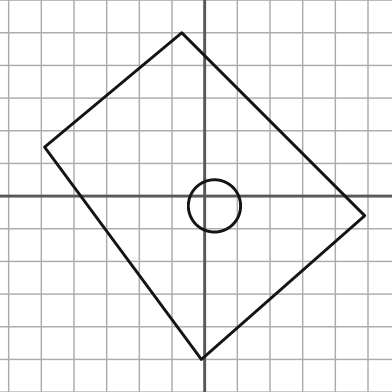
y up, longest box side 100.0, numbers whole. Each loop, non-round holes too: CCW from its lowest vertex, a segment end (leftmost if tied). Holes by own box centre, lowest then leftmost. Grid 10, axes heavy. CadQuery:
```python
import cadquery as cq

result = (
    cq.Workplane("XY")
    .moveTo(-1.0, -50.0)
    .lineTo(49.0, -6.0)
    .lineTo(-7.0, 50.0)
    .lineTo(-49.0, 15.0)
    .close()
    .moveTo(3.0, -3.0)
    .circle(8.0)
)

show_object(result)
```